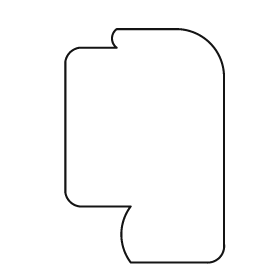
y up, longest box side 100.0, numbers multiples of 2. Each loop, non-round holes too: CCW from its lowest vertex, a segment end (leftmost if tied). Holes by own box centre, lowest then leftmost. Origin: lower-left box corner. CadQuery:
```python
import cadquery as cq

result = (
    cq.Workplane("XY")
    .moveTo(28.0, 0.0)
    .lineTo(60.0, 0.0)
    .threePointArc((66.0, 2.0), (68.0, 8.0))
    .lineTo(68.0, 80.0)
    .threePointArc((62.0, 94.0), (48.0, 100.0))
    .lineTo(22.0, 100.0)
    .threePointArc((20.0, 96.0), (22.0, 92.0))
    .lineTo(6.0, 92.0)
    .threePointArc((2.0, 90.0), (0.0, 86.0))
    .lineTo(0.0, 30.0)
    .threePointArc((2.0, 26.0), (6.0, 24.0))
    .lineTo(28.0, 24.0)
    .threePointArc((24.0, 12.0), (28.0, 0.0))
    .close()
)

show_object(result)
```